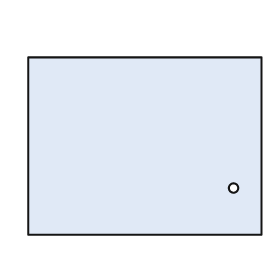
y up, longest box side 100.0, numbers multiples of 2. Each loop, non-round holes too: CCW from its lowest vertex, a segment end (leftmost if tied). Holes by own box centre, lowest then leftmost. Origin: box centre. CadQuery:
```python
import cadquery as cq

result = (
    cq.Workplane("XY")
    .moveTo(-50.0, -38.0)
    .lineTo(50.0, -38.0)
    .lineTo(50.0, 38.0)
    .lineTo(-50.0, 38.0)
    .close()
    .moveTo(38.0, -18.0)
    .circle(2.0)
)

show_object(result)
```